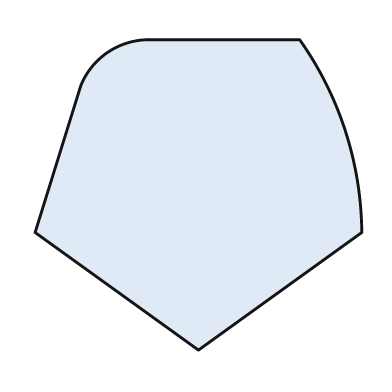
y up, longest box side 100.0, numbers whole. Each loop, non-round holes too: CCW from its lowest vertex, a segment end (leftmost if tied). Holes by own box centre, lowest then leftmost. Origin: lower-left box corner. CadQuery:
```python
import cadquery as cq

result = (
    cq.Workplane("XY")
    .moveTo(50.0, 0.0)
    .lineTo(100.0, 36.0)
    .threePointArc((95.0, 67.0), (81.0, 95.0))
    .lineTo(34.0, 95.0)
    .threePointArc((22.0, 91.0), (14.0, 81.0))
    .lineTo(0.0, 36.0)
    .close()
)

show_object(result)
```